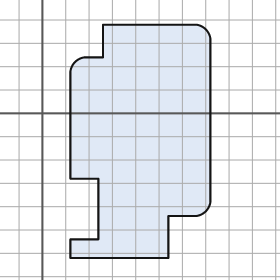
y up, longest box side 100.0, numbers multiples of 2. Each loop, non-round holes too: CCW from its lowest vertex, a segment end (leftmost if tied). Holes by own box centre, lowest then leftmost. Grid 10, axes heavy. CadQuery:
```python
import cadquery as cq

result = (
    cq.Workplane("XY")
    .moveTo(12.0, -62.0)
    .lineTo(54.0, -62.0)
    .lineTo(54.0, -44.0)
    .lineTo(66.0, -44.0)
    .threePointArc((70.0, -42.0), (72.0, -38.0))
    .lineTo(72.0, 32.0)
    .threePointArc((70.0, 36.0), (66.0, 38.0))
    .lineTo(26.0, 38.0)
    .lineTo(26.0, 24.0)
    .lineTo(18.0, 24.0)
    .threePointArc((14.0, 22.0), (12.0, 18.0))
    .lineTo(12.0, -28.0)
    .lineTo(24.0, -28.0)
    .lineTo(24.0, -54.0)
    .lineTo(12.0, -54.0)
    .close()
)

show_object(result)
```